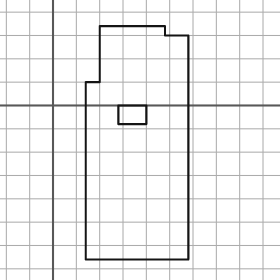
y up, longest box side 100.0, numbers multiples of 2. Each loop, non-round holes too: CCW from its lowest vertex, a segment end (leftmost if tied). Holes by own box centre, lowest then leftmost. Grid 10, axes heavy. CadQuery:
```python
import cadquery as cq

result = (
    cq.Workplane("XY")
    .moveTo(14.0, -66.0)
    .lineTo(58.0, -66.0)
    .lineTo(58.0, 30.0)
    .lineTo(48.0, 30.0)
    .lineTo(48.0, 34.0)
    .lineTo(20.0, 34.0)
    .lineTo(20.0, 10.0)
    .lineTo(14.0, 10.0)
    .close()
    .moveTo(28.0, -8.0)
    .lineTo(40.0, -8.0)
    .lineTo(40.0, 0.0)
    .lineTo(28.0, 0.0)
    .close()
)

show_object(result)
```